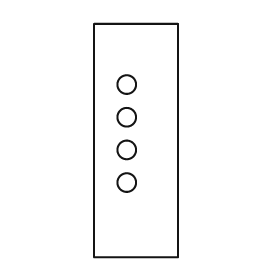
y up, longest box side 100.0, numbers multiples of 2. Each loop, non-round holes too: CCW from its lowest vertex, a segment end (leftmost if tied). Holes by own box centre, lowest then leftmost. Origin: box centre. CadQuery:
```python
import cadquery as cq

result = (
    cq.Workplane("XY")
    .moveTo(-18.0, -50.0)
    .lineTo(18.0, -50.0)
    .lineTo(18.0, 50.0)
    .lineTo(-18.0, 50.0)
    .close()
    .moveTo(-4.0, -18.0)
    .circle(4.0)
    .moveTo(-4.0, -4.0)
    .circle(4.0)
    .moveTo(-4.0, 10.0)
    .circle(4.0)
    .moveTo(-4.0, 24.0)
    .circle(4.0)
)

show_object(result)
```